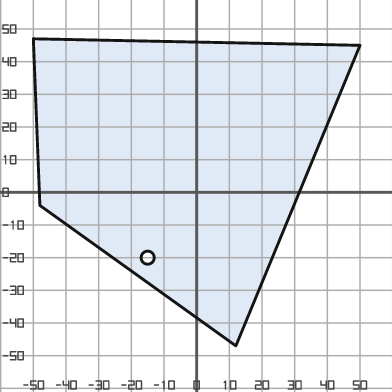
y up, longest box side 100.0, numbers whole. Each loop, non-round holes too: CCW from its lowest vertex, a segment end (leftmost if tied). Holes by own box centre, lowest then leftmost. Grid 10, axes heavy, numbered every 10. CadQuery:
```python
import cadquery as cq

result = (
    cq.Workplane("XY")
    .moveTo(12.0, -47.0)
    .lineTo(50.0, 45.0)
    .lineTo(-50.0, 47.0)
    .lineTo(-48.0, -4.0)
    .close()
    .moveTo(-15.0, -20.0)
    .circle(2.0)
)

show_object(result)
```